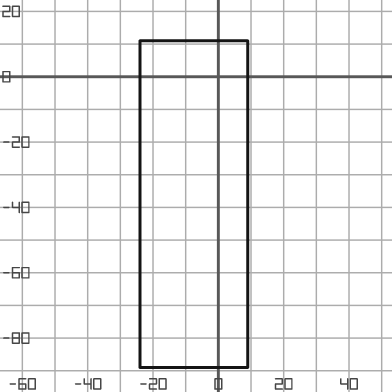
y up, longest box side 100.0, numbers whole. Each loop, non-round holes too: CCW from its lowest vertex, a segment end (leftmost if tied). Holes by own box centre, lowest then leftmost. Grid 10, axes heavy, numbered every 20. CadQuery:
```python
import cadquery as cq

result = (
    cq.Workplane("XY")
    .moveTo(-24.0, -89.0)
    .lineTo(9.0, -89.0)
    .lineTo(9.0, 11.0)
    .lineTo(-24.0, 11.0)
    .close()
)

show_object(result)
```